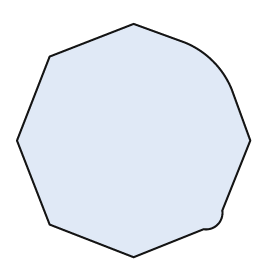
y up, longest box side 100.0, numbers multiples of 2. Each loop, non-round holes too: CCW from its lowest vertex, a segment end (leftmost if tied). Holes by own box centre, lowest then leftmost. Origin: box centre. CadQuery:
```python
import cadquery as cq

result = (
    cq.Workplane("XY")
    .moveTo(0.0, -50.0)
    .lineTo(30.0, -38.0)
    .threePointArc((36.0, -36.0), (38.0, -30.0))
    .lineTo(50.0, 0.0)
    .lineTo(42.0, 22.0)
    .threePointArc((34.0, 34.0), (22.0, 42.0))
    .lineTo(0.0, 50.0)
    .lineTo(-36.0, 36.0)
    .lineTo(-50.0, 0.0)
    .lineTo(-36.0, -36.0)
    .close()
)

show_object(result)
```